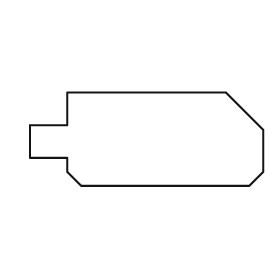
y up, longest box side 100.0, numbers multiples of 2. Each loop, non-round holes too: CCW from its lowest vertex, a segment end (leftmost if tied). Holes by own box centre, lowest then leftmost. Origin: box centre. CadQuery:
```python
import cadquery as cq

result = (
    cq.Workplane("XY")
    .moveTo(-28.0, -20.0)
    .lineTo(44.0, -20.0)
    .lineTo(50.0, -14.0)
    .lineTo(50.0, 4.0)
    .lineTo(34.0, 20.0)
    .lineTo(-34.0, 20.0)
    .lineTo(-34.0, 6.0)
    .lineTo(-50.0, 6.0)
    .lineTo(-50.0, -8.0)
    .lineTo(-34.0, -8.0)
    .lineTo(-34.0, -14.0)
    .close()
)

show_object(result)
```